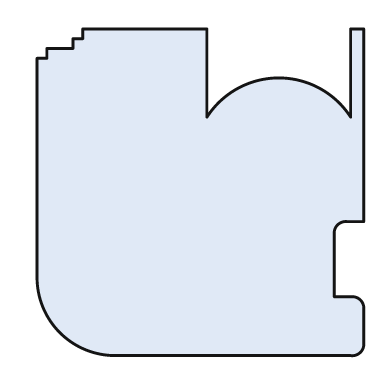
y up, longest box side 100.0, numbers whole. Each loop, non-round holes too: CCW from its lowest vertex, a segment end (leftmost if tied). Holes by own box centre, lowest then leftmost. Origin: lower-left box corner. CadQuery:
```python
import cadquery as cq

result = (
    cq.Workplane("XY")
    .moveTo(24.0, 0.0)
    .lineTo(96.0, 0.0)
    .threePointArc((99.0, 1.0), (100.0, 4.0))
    .lineTo(100.0, 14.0)
    .threePointArc((99.0, 17.0), (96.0, 18.0))
    .lineTo(91.0, 18.0)
    .lineTo(91.0, 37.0)
    .threePointArc((92.0, 40.0), (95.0, 41.0))
    .lineTo(100.0, 41.0)
    .lineTo(100.0, 100.0)
    .lineTo(96.0, 100.0)
    .lineTo(96.0, 73.0)
    .threePointArc((74.0, 85.0), (52.0, 73.0))
    .lineTo(52.0, 100.0)
    .lineTo(14.0, 100.0)
    .lineTo(14.0, 97.0)
    .lineTo(11.0, 97.0)
    .lineTo(11.0, 94.0)
    .lineTo(3.0, 94.0)
    .lineTo(3.0, 91.0)
    .lineTo(0.0, 91.0)
    .lineTo(0.0, 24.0)
    .threePointArc((7.0, 7.0), (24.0, 0.0))
    .close()
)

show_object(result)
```